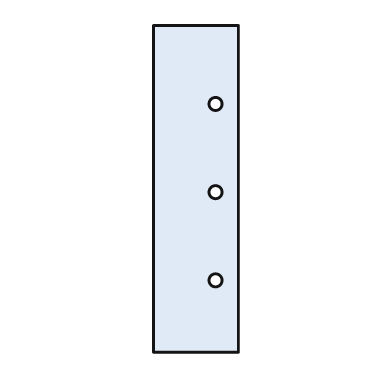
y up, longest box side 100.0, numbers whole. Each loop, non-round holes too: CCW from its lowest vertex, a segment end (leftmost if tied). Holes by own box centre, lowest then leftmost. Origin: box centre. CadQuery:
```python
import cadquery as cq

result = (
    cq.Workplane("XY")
    .moveTo(-13.0, -50.0)
    .lineTo(13.0, -50.0)
    .lineTo(13.0, 50.0)
    .lineTo(-13.0, 50.0)
    .close()
    .moveTo(6.0, -28.0)
    .circle(2.0)
    .moveTo(6.0, -1.0)
    .circle(2.0)
    .moveTo(6.0, 26.0)
    .circle(2.0)
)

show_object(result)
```